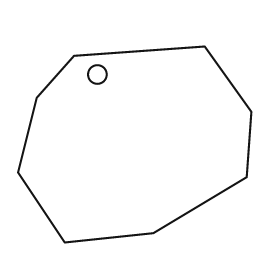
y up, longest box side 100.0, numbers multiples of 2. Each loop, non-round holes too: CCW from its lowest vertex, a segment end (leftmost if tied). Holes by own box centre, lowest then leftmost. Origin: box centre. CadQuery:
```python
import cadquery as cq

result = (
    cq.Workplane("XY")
    .moveTo(-30.0, -42.0)
    .lineTo(8.0, -38.0)
    .lineTo(48.0, -14.0)
    .lineTo(50.0, 14.0)
    .lineTo(30.0, 42.0)
    .lineTo(-26.0, 38.0)
    .lineTo(-42.0, 20.0)
    .lineTo(-50.0, -12.0)
    .close()
    .moveTo(-16.0, 30.0)
    .circle(4.0)
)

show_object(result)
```